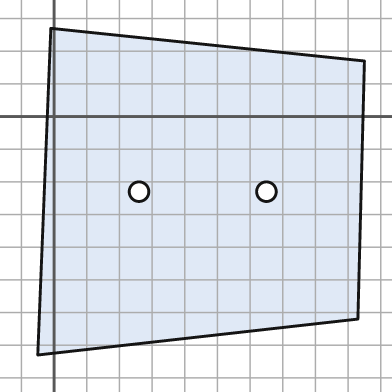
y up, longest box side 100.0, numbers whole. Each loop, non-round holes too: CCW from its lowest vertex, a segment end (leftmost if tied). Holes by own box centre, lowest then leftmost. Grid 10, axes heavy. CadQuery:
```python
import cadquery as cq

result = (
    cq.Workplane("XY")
    .moveTo(-5.0, -73.0)
    .lineTo(93.0, -62.0)
    .lineTo(95.0, 17.0)
    .lineTo(-1.0, 27.0)
    .close()
    .moveTo(26.0, -23.0)
    .circle(3.0)
    .moveTo(65.0, -23.0)
    .circle(3.0)
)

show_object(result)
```